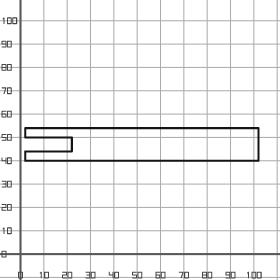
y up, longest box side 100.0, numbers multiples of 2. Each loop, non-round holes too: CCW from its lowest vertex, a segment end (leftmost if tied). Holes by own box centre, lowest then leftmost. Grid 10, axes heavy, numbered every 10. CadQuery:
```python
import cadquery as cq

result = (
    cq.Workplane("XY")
    .moveTo(2.0, 40.0)
    .lineTo(102.0, 40.0)
    .lineTo(102.0, 54.0)
    .lineTo(2.0, 54.0)
    .lineTo(2.0, 50.0)
    .lineTo(22.0, 50.0)
    .lineTo(22.0, 44.0)
    .lineTo(2.0, 44.0)
    .close()
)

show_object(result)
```